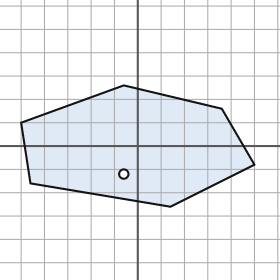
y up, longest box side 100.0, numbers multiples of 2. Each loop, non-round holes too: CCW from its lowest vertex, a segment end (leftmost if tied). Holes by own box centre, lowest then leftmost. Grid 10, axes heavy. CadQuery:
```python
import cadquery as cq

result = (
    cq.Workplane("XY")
    .moveTo(14.0, -26.0)
    .lineTo(50.0, -8.0)
    .lineTo(36.0, 16.0)
    .lineTo(-6.0, 26.0)
    .lineTo(-50.0, 10.0)
    .lineTo(-46.0, -16.0)
    .close()
    .moveTo(-6.0, -12.0)
    .circle(2.0)
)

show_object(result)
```